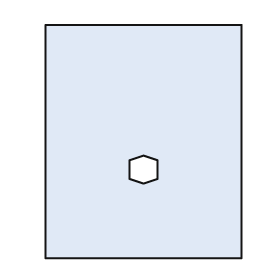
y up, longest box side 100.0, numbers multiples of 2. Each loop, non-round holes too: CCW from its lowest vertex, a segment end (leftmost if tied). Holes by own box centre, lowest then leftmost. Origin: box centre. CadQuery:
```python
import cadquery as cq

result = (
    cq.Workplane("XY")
    .moveTo(-42.0, -50.0)
    .lineTo(42.0, -50.0)
    .lineTo(42.0, 50.0)
    .lineTo(-42.0, 50.0)
    .close()
    .moveTo(0.0, -18.0)
    .lineTo(6.0, -16.0)
    .lineTo(6.0, -8.0)
    .lineTo(0.0, -6.0)
    .lineTo(-6.0, -8.0)
    .lineTo(-6.0, -16.0)
    .close()
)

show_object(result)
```